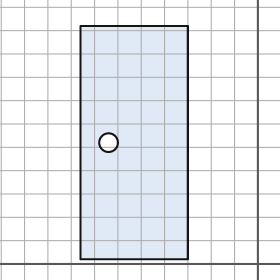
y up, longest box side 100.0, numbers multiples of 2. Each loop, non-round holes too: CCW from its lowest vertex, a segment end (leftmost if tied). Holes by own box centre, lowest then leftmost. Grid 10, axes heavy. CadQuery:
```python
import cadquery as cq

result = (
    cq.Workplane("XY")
    .moveTo(-76.0, 2.0)
    .lineTo(-30.0, 2.0)
    .lineTo(-30.0, 102.0)
    .lineTo(-76.0, 102.0)
    .close()
    .moveTo(-64.0, 52.0)
    .circle(4.0)
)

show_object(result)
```